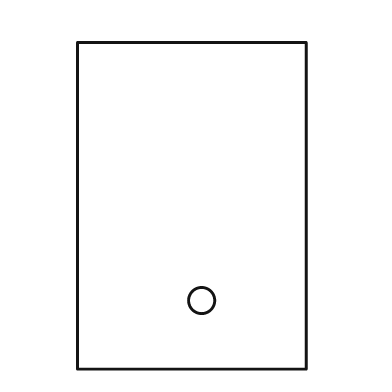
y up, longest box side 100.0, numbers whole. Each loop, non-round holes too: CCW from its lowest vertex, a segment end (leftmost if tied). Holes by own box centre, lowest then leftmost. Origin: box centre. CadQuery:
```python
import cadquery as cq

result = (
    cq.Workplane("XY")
    .moveTo(-35.0, -50.0)
    .lineTo(35.0, -50.0)
    .lineTo(35.0, 50.0)
    .lineTo(-35.0, 50.0)
    .close()
    .moveTo(3.0, -29.0)
    .circle(4.0)
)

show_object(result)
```